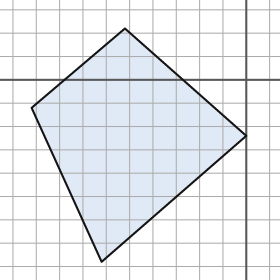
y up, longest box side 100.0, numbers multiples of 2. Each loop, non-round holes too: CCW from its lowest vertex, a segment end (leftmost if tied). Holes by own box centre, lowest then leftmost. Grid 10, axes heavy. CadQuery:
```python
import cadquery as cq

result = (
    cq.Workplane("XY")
    .moveTo(-62.0, -78.0)
    .lineTo(0.0, -24.0)
    .lineTo(-52.0, 22.0)
    .lineTo(-92.0, -12.0)
    .close()
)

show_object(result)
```